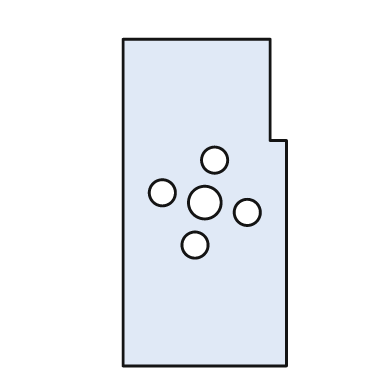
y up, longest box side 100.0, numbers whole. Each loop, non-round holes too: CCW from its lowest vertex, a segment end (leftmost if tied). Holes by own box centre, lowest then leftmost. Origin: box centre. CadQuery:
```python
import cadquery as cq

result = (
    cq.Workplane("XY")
    .moveTo(-25.0, -50.0)
    .lineTo(25.0, -50.0)
    .lineTo(25.0, 19.0)
    .lineTo(20.0, 19.0)
    .lineTo(20.0, 50.0)
    .lineTo(-25.0, 50.0)
    .close()
    .moveTo(-3.0, -13.0)
    .circle(4.0)
    .moveTo(13.0, -3.0)
    .circle(4.0)
    .moveTo(0.0, 0.0)
    .circle(5.0)
    .moveTo(-13.0, 3.0)
    .circle(4.0)
    .moveTo(3.0, 13.0)
    .circle(4.0)
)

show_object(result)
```